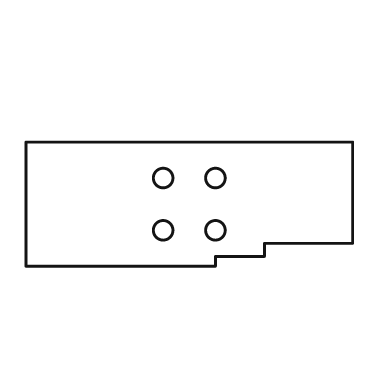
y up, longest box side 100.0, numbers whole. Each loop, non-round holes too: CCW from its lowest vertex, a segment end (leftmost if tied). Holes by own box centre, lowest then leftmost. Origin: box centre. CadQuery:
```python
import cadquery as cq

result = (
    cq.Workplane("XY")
    .moveTo(-50.0, -19.0)
    .lineTo(8.0, -19.0)
    .lineTo(8.0, -16.0)
    .lineTo(23.0, -16.0)
    .lineTo(23.0, -12.0)
    .lineTo(50.0, -12.0)
    .lineTo(50.0, 19.0)
    .lineTo(-50.0, 19.0)
    .close()
    .moveTo(-8.0, -8.0)
    .circle(3.0)
    .moveTo(8.0, -8.0)
    .circle(3.0)
    .moveTo(-8.0, 8.0)
    .circle(3.0)
    .moveTo(8.0, 8.0)
    .circle(3.0)
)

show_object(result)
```